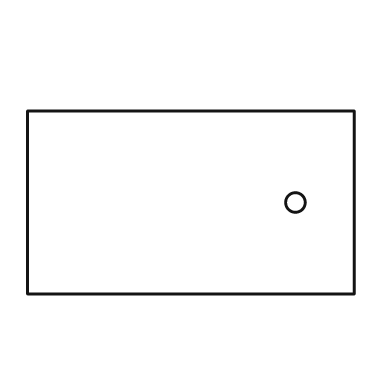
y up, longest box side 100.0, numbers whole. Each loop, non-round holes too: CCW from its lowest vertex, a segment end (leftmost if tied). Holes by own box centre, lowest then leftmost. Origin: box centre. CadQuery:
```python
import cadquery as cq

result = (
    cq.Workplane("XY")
    .moveTo(-50.0, -28.0)
    .lineTo(50.0, -28.0)
    .lineTo(50.0, 28.0)
    .lineTo(-50.0, 28.0)
    .close()
    .moveTo(32.0, 0.0)
    .circle(3.0)
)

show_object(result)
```